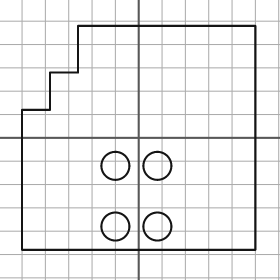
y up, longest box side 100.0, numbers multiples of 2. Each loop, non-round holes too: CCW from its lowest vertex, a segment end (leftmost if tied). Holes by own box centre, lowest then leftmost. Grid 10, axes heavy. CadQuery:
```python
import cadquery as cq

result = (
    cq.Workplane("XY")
    .moveTo(-50.0, -48.0)
    .lineTo(50.0, -48.0)
    .lineTo(50.0, 48.0)
    .lineTo(-26.0, 48.0)
    .lineTo(-26.0, 28.0)
    .lineTo(-38.0, 28.0)
    .lineTo(-38.0, 12.0)
    .lineTo(-50.0, 12.0)
    .close()
    .moveTo(-10.0, -38.0)
    .circle(6.0)
    .moveTo(8.0, -38.0)
    .circle(6.0)
    .moveTo(-10.0, -12.0)
    .circle(6.0)
    .moveTo(8.0, -12.0)
    .circle(6.0)
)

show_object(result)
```